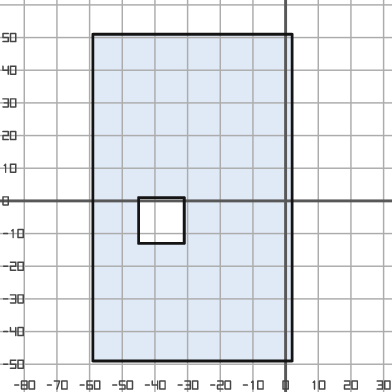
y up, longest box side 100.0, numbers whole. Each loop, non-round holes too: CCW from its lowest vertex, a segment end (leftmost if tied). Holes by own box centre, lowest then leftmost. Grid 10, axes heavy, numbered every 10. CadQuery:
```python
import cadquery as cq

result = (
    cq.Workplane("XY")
    .moveTo(-59.0, -49.0)
    .lineTo(2.0, -49.0)
    .lineTo(2.0, 51.0)
    .lineTo(-59.0, 51.0)
    .close()
    .moveTo(-45.0, -13.0)
    .lineTo(-31.0, -13.0)
    .lineTo(-31.0, 1.0)
    .lineTo(-45.0, 1.0)
    .close()
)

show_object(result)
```